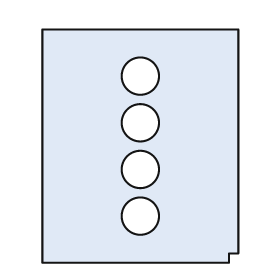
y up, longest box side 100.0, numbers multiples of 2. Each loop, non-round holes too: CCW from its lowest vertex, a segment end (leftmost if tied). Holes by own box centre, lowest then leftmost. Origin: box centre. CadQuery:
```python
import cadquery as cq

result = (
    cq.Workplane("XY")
    .moveTo(-42.0, -50.0)
    .lineTo(38.0, -50.0)
    .lineTo(38.0, -46.0)
    .lineTo(42.0, -46.0)
    .lineTo(42.0, 50.0)
    .lineTo(-42.0, 50.0)
    .close()
    .moveTo(0.0, -30.0)
    .circle(8.0)
    .moveTo(0.0, -10.0)
    .circle(8.0)
    .moveTo(0.0, 10.0)
    .circle(8.0)
    .moveTo(0.0, 30.0)
    .circle(8.0)
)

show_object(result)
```